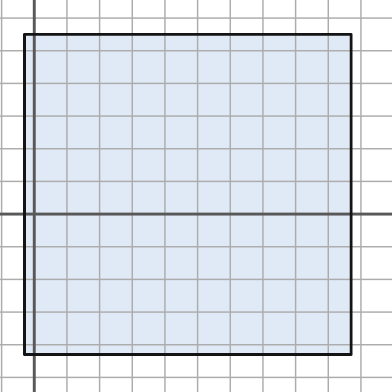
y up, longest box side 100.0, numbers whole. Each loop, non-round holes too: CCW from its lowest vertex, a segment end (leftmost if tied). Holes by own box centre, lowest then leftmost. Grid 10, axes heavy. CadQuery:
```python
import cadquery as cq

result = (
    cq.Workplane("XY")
    .moveTo(-3.0, -43.0)
    .lineTo(97.0, -43.0)
    .lineTo(97.0, 55.0)
    .lineTo(-3.0, 55.0)
    .close()
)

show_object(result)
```